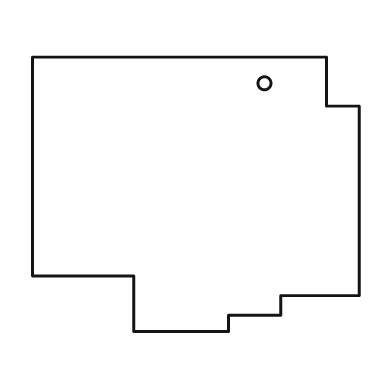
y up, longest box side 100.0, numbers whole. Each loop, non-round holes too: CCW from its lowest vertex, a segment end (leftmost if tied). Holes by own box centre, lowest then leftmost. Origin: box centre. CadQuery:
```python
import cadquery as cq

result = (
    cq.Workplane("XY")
    .moveTo(-19.0, -42.0)
    .lineTo(10.0, -42.0)
    .lineTo(10.0, -37.0)
    .lineTo(26.0, -37.0)
    .lineTo(26.0, -31.0)
    .lineTo(50.0, -31.0)
    .lineTo(50.0, 27.0)
    .lineTo(40.0, 27.0)
    .lineTo(40.0, 42.0)
    .lineTo(-50.0, 42.0)
    .lineTo(-50.0, -25.0)
    .lineTo(-19.0, -25.0)
    .close()
    .moveTo(21.0, 34.0)
    .circle(2.0)
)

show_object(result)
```